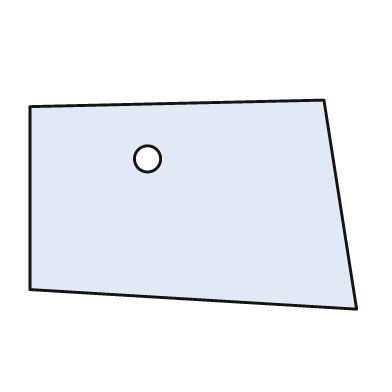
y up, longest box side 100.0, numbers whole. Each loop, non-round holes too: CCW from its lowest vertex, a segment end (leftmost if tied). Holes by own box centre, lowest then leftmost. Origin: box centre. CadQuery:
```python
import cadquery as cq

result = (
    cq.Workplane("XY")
    .moveTo(50.0, -32.0)
    .lineTo(40.0, 32.0)
    .lineTo(-50.0, 30.0)
    .lineTo(-50.0, -26.0)
    .close()
    .moveTo(-14.0, 14.0)
    .circle(4.0)
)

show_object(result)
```